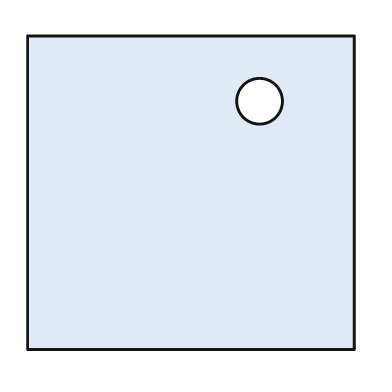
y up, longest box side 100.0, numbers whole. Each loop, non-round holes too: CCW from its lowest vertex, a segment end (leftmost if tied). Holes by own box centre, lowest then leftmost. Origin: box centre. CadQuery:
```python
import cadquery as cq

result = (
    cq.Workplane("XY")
    .moveTo(-50.0, -48.0)
    .lineTo(50.0, -48.0)
    .lineTo(50.0, 48.0)
    .lineTo(-50.0, 48.0)
    .close()
    .moveTo(21.0, 28.0)
    .circle(7.0)
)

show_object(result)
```